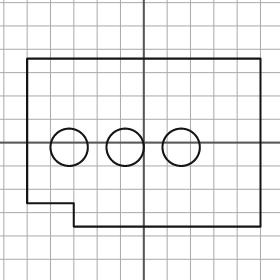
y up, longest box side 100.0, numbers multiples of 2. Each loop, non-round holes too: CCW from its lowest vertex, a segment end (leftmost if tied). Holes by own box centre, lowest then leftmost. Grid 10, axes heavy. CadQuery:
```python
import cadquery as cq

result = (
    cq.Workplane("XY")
    .moveTo(-30.0, -36.0)
    .lineTo(50.0, -36.0)
    .lineTo(50.0, 36.0)
    .lineTo(-50.0, 36.0)
    .lineTo(-50.0, -26.0)
    .lineTo(-30.0, -26.0)
    .close()
    .moveTo(-32.0, -2.0)
    .circle(8.0)
    .moveTo(-8.0, -2.0)
    .circle(8.0)
    .moveTo(16.0, -2.0)
    .circle(8.0)
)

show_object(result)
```